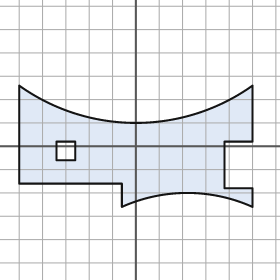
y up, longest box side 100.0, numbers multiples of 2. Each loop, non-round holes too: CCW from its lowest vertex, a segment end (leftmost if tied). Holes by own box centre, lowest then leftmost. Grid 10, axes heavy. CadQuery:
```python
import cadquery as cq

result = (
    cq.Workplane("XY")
    .moveTo(-6.0, -26.0)
    .threePointArc((22.0, -20.0), (50.0, -26.0))
    .lineTo(50.0, -18.0)
    .lineTo(38.0, -18.0)
    .lineTo(38.0, 2.0)
    .lineTo(50.0, 2.0)
    .lineTo(50.0, 26.0)
    .threePointArc((0.0, 10.0), (-50.0, 26.0))
    .lineTo(-50.0, -16.0)
    .lineTo(-6.0, -16.0)
    .close()
    .moveTo(-34.0, -6.0)
    .lineTo(-26.0, -6.0)
    .lineTo(-26.0, 2.0)
    .lineTo(-34.0, 2.0)
    .close()
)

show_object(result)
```